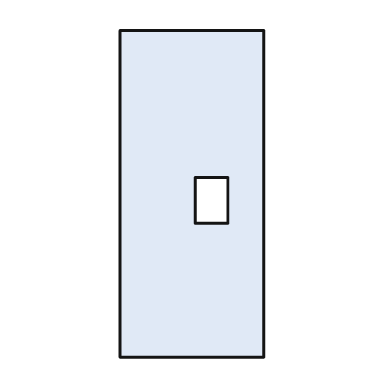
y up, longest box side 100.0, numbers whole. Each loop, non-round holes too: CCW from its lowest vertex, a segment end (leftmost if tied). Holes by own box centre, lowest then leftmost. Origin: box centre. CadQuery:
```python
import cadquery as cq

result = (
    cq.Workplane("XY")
    .moveTo(-22.0, -50.0)
    .lineTo(22.0, -50.0)
    .lineTo(22.0, 50.0)
    .lineTo(-22.0, 50.0)
    .close()
    .moveTo(1.0, -9.0)
    .lineTo(11.0, -9.0)
    .lineTo(11.0, 5.0)
    .lineTo(1.0, 5.0)
    .close()
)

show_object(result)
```